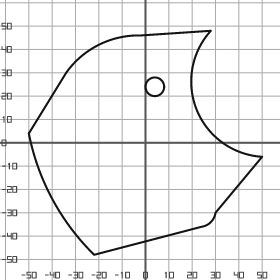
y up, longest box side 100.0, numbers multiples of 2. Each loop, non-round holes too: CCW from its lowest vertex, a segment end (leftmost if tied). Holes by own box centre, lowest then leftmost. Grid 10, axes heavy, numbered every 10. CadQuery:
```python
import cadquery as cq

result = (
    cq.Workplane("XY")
    .moveTo(-22.0, -48.0)
    .lineTo(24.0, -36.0)
    .threePointArc((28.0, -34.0), (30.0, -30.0))
    .lineTo(50.0, -6.0)
    .threePointArc((22.0, 14.0), (28.0, 48.0))
    .lineTo(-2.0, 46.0)
    .threePointArc((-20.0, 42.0), (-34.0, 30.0))
    .lineTo(-50.0, 4.0)
    .threePointArc((-40.0, -24.0), (-22.0, -48.0))
    .close()
    .moveTo(4.0, 24.0)
    .circle(4.0)
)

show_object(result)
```